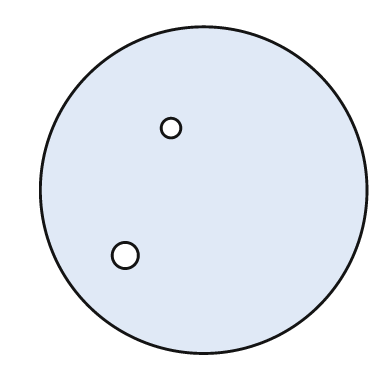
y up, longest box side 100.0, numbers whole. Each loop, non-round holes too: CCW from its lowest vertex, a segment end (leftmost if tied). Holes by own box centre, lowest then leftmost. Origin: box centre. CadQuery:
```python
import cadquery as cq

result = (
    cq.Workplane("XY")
    .moveTo(0.0, 0.0)
    .circle(50.0)
    .moveTo(-24.0, -20.0)
    .circle(4.0)
    .moveTo(-10.0, 19.0)
    .circle(3.0)
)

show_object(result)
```